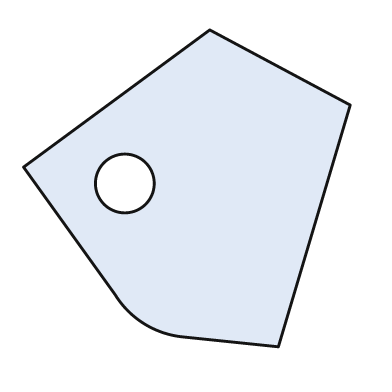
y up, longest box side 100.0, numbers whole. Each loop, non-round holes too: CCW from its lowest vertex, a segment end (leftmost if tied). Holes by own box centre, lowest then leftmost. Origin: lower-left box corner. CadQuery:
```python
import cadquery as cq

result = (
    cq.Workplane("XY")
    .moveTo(78.0, 0.0)
    .lineTo(100.0, 74.0)
    .lineTo(57.0, 97.0)
    .lineTo(0.0, 55.0)
    .lineTo(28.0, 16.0)
    .threePointArc((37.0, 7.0), (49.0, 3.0))
    .close()
    .moveTo(31.0, 50.0)
    .circle(9.0)
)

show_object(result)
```